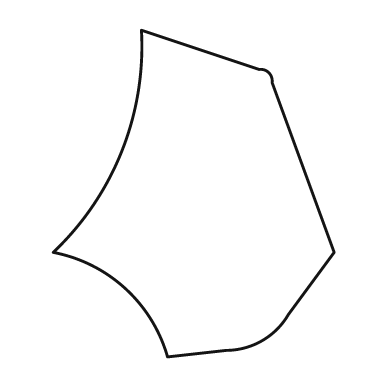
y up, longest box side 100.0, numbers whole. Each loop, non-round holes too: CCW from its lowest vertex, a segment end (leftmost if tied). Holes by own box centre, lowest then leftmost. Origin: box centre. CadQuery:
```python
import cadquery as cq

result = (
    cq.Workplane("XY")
    .moveTo(-8.0, -50.0)
    .lineTo(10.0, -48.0)
    .threePointArc((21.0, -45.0), (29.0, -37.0))
    .lineTo(43.0, -18.0)
    .lineTo(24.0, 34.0)
    .threePointArc((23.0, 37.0), (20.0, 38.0))
    .lineTo(-16.0, 50.0)
    .threePointArc((-22.0, 13.0), (-43.0, -18.0))
    .threePointArc((-21.0, -29.0), (-8.0, -50.0))
    .close()
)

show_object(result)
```